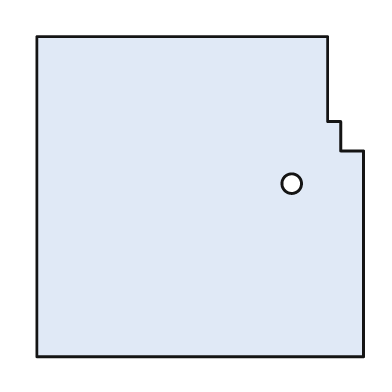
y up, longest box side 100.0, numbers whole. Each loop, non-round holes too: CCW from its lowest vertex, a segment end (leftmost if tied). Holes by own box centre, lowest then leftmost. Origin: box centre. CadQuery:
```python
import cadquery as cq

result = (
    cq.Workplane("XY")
    .moveTo(-50.0, -49.0)
    .lineTo(50.0, -49.0)
    .lineTo(50.0, 14.0)
    .lineTo(43.0, 14.0)
    .lineTo(43.0, 23.0)
    .lineTo(39.0, 23.0)
    .lineTo(39.0, 49.0)
    .lineTo(-50.0, 49.0)
    .close()
    .moveTo(28.0, 4.0)
    .circle(3.0)
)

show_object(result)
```